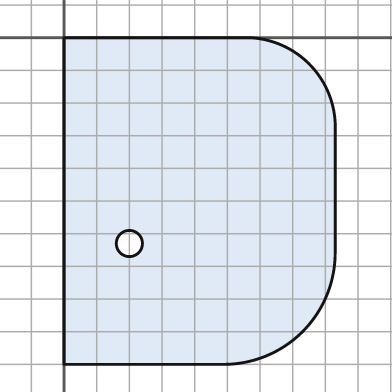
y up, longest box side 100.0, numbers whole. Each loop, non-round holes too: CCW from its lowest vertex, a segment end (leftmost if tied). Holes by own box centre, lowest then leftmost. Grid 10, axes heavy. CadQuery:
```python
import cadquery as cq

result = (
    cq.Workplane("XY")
    .moveTo(0.0, -100.0)
    .lineTo(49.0, -100.0)
    .threePointArc((73.0, -90.0), (83.0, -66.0))
    .lineTo(83.0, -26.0)
    .threePointArc((75.0, -8.0), (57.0, 0.0))
    .lineTo(0.0, 0.0)
    .close()
    .moveTo(20.0, -63.0)
    .circle(4.0)
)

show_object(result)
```